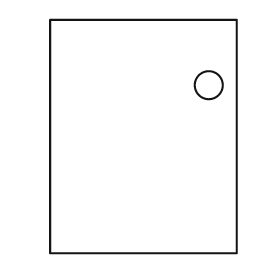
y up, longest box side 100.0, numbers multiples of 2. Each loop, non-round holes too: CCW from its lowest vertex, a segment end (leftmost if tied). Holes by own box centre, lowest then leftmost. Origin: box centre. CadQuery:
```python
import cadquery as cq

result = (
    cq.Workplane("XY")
    .moveTo(-40.0, -50.0)
    .lineTo(40.0, -50.0)
    .lineTo(40.0, 50.0)
    .lineTo(-40.0, 50.0)
    .close()
    .moveTo(28.0, 22.0)
    .circle(6.0)
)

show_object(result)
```